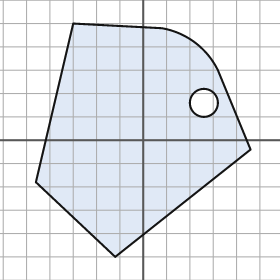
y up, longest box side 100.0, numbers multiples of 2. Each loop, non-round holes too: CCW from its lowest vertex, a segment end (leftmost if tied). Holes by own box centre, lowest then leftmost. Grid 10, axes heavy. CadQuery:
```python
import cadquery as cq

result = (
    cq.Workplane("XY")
    .moveTo(-12.0, -50.0)
    .lineTo(46.0, -4.0)
    .lineTo(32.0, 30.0)
    .threePointArc((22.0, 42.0), (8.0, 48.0))
    .lineTo(-30.0, 50.0)
    .lineTo(-46.0, -18.0)
    .close()
    .moveTo(26.0, 16.0)
    .circle(6.0)
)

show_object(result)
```